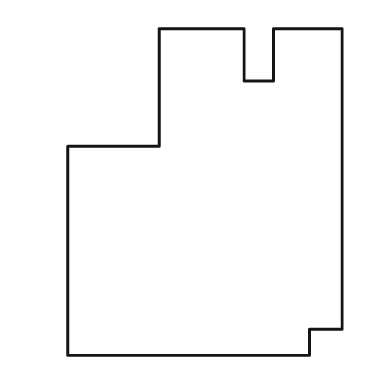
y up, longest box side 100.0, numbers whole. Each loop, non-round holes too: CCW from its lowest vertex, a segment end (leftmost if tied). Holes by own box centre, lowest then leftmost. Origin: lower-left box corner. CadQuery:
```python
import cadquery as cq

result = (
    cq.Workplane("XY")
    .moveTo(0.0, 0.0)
    .lineTo(74.0, 0.0)
    .lineTo(74.0, 8.0)
    .lineTo(84.0, 8.0)
    .lineTo(84.0, 100.0)
    .lineTo(63.0, 100.0)
    .lineTo(63.0, 84.0)
    .lineTo(54.0, 84.0)
    .lineTo(54.0, 100.0)
    .lineTo(28.0, 100.0)
    .lineTo(28.0, 64.0)
    .lineTo(0.0, 64.0)
    .close()
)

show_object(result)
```